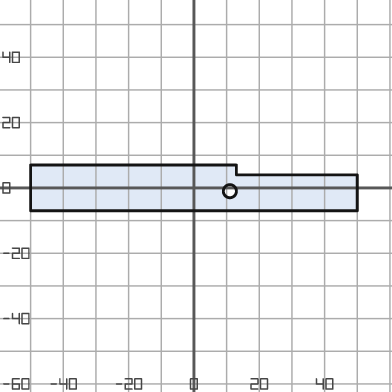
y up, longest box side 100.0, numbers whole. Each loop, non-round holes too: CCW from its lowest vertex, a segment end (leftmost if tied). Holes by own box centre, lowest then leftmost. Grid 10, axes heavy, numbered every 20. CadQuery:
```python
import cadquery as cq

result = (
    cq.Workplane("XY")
    .moveTo(-50.0, -7.0)
    .lineTo(50.0, -7.0)
    .lineTo(50.0, 4.0)
    .lineTo(13.0, 4.0)
    .lineTo(13.0, 7.0)
    .lineTo(-50.0, 7.0)
    .close()
    .moveTo(11.0, -1.0)
    .circle(2.0)
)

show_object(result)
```